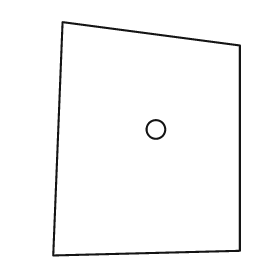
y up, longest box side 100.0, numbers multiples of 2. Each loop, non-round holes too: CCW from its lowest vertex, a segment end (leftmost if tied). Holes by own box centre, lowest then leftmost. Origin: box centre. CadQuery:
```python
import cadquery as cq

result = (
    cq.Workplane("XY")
    .moveTo(-40.0, -50.0)
    .lineTo(40.0, -48.0)
    .lineTo(40.0, 40.0)
    .lineTo(-36.0, 50.0)
    .close()
    .moveTo(4.0, 4.0)
    .circle(4.0)
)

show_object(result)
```